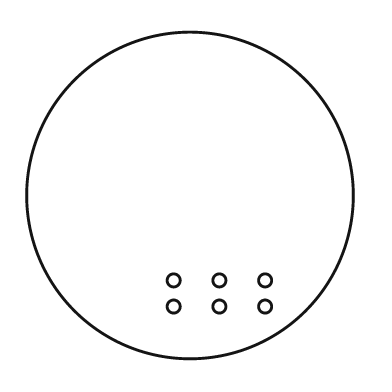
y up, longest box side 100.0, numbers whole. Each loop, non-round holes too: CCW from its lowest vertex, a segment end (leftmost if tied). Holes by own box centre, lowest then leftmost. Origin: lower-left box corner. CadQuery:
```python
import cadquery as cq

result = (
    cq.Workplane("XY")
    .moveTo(50.0, 50.0)
    .circle(50.0)
    .moveTo(45.0, 16.0)
    .circle(2.0)
    .moveTo(59.0, 16.0)
    .circle(2.0)
    .moveTo(73.0, 16.0)
    .circle(2.0)
    .moveTo(45.0, 24.0)
    .circle(2.0)
    .moveTo(59.0, 24.0)
    .circle(2.0)
    .moveTo(73.0, 24.0)
    .circle(2.0)
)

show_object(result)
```